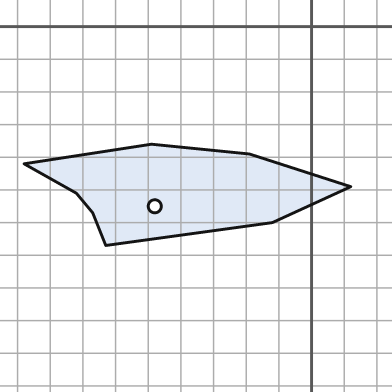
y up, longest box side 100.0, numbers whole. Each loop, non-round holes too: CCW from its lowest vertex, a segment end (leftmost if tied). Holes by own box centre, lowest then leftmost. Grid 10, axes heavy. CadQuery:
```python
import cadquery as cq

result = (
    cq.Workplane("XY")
    .moveTo(-63.0, -67.0)
    .lineTo(-12.0, -60.0)
    .lineTo(12.0, -49.0)
    .lineTo(-19.0, -39.0)
    .lineTo(-49.0, -36.0)
    .lineTo(-88.0, -42.0)
    .lineTo(-72.0, -51.0)
    .lineTo(-67.0, -57.0)
    .close()
    .moveTo(-48.0, -55.0)
    .circle(2.0)
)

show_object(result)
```